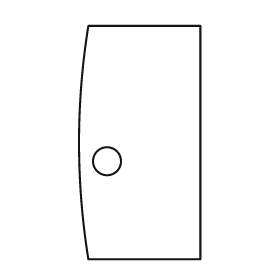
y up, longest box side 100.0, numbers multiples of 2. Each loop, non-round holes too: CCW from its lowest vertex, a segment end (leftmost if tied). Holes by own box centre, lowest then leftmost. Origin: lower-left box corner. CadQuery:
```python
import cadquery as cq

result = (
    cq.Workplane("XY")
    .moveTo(4.0, 0.0)
    .lineTo(52.0, 0.0)
    .lineTo(52.0, 100.0)
    .lineTo(4.0, 100.0)
    .threePointArc((0.0, 50.0), (4.0, 0.0))
    .close()
    .moveTo(12.0, 42.0)
    .circle(6.0)
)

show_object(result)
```